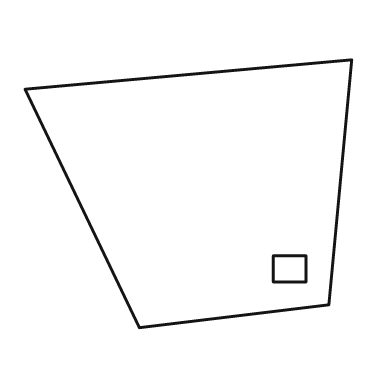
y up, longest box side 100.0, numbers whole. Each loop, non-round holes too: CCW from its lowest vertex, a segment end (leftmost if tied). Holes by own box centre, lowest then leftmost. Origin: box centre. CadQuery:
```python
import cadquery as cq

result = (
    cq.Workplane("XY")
    .moveTo(-15.0, -41.0)
    .lineTo(43.0, -34.0)
    .lineTo(50.0, 41.0)
    .lineTo(-50.0, 32.0)
    .close()
    .moveTo(26.0, -27.0)
    .lineTo(36.0, -27.0)
    .lineTo(36.0, -19.0)
    .lineTo(26.0, -19.0)
    .close()
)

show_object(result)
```